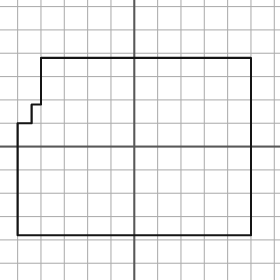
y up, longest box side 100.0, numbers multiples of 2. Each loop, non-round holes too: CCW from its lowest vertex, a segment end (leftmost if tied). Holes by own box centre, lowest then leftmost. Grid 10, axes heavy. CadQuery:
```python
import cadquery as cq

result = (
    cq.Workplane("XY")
    .moveTo(-50.0, -38.0)
    .lineTo(50.0, -38.0)
    .lineTo(50.0, 38.0)
    .lineTo(-40.0, 38.0)
    .lineTo(-40.0, 18.0)
    .lineTo(-44.0, 18.0)
    .lineTo(-44.0, 10.0)
    .lineTo(-50.0, 10.0)
    .close()
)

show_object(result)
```